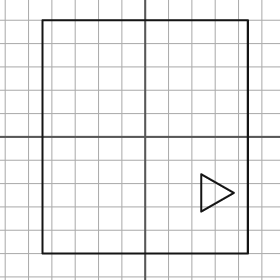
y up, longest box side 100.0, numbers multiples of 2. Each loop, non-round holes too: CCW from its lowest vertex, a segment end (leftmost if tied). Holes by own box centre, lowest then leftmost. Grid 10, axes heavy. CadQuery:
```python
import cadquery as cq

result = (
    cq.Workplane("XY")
    .moveTo(-44.0, -50.0)
    .lineTo(44.0, -50.0)
    .lineTo(44.0, 50.0)
    .lineTo(-44.0, 50.0)
    .close()
    .moveTo(24.0, -32.0)
    .lineTo(38.0, -24.0)
    .lineTo(24.0, -16.0)
    .close()
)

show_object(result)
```